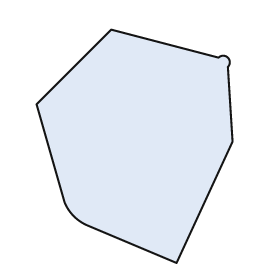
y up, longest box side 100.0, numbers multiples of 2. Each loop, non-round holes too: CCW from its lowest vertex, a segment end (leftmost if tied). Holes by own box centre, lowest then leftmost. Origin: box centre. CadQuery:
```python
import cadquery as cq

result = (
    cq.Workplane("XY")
    .moveTo(18.0, -50.0)
    .lineTo(42.0, 2.0)
    .lineTo(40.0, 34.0)
    .threePointArc((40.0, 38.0), (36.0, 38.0))
    .lineTo(-10.0, 50.0)
    .lineTo(-42.0, 18.0)
    .lineTo(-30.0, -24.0)
    .threePointArc((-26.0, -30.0), (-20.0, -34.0))
    .close()
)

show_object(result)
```